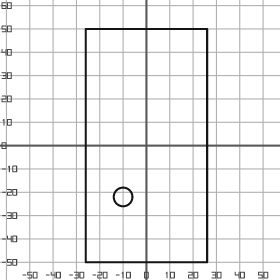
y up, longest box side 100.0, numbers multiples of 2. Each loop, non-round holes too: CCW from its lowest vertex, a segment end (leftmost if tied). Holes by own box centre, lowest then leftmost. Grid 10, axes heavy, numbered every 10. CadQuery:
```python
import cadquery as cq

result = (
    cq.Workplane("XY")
    .moveTo(-26.0, -50.0)
    .lineTo(26.0, -50.0)
    .lineTo(26.0, 50.0)
    .lineTo(-26.0, 50.0)
    .close()
    .moveTo(-10.0, -22.0)
    .circle(4.0)
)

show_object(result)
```